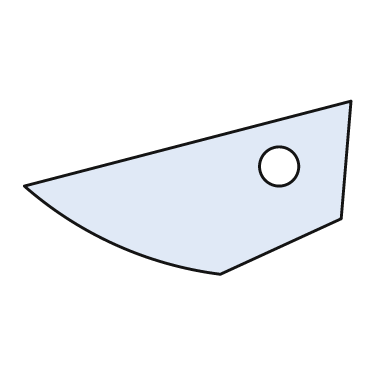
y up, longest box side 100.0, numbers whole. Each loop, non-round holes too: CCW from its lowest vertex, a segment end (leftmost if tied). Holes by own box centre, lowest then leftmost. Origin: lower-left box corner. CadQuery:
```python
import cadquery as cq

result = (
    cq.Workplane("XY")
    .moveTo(60.0, 0.0)
    .lineTo(97.0, 17.0)
    .lineTo(100.0, 53.0)
    .lineTo(0.0, 27.0)
    .threePointArc((28.0, 9.0), (60.0, 0.0))
    .close()
    .moveTo(78.0, 33.0)
    .circle(6.0)
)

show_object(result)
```